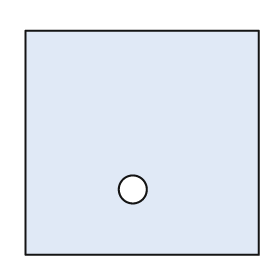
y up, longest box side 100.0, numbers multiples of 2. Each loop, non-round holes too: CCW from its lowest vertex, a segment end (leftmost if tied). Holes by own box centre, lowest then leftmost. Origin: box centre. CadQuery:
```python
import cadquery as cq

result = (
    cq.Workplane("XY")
    .moveTo(-50.0, -48.0)
    .lineTo(50.0, -48.0)
    .lineTo(50.0, 48.0)
    .lineTo(-50.0, 48.0)
    .close()
    .moveTo(-4.0, -20.0)
    .circle(6.0)
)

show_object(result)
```